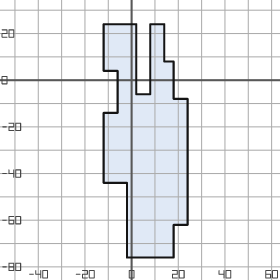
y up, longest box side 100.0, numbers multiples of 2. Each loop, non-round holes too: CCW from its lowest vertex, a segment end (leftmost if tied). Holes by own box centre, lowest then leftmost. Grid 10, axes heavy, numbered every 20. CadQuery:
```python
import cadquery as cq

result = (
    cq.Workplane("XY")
    .moveTo(-2.0, -76.0)
    .lineTo(18.0, -76.0)
    .lineTo(18.0, -62.0)
    .lineTo(24.0, -62.0)
    .lineTo(24.0, -8.0)
    .lineTo(18.0, -8.0)
    .lineTo(18.0, 8.0)
    .lineTo(14.0, 8.0)
    .lineTo(14.0, 24.0)
    .lineTo(8.0, 24.0)
    .lineTo(8.0, -6.0)
    .lineTo(2.0, -6.0)
    .lineTo(2.0, 24.0)
    .lineTo(-12.0, 24.0)
    .lineTo(-12.0, 4.0)
    .lineTo(-6.0, 4.0)
    .lineTo(-6.0, -14.0)
    .lineTo(-12.0, -14.0)
    .lineTo(-12.0, -44.0)
    .lineTo(-2.0, -44.0)
    .close()
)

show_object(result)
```